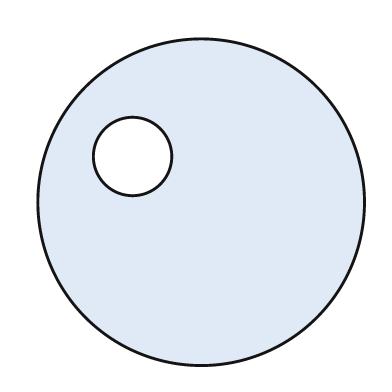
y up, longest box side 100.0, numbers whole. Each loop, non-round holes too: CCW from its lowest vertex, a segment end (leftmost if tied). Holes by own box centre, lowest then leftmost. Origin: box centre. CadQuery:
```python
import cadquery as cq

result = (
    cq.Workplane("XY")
    .moveTo(0.0, 0.0)
    .circle(50.0)
    .moveTo(-21.0, 14.0)
    .circle(12.0)
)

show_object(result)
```